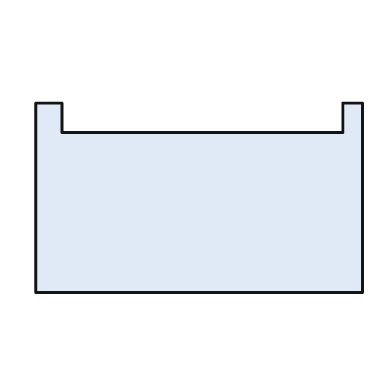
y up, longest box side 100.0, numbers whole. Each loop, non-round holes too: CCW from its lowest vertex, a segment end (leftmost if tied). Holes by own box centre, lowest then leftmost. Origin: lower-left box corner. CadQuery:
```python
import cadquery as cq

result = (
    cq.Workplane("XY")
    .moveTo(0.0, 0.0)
    .lineTo(100.0, 0.0)
    .lineTo(100.0, 58.0)
    .lineTo(94.0, 58.0)
    .lineTo(94.0, 49.0)
    .lineTo(8.0, 49.0)
    .lineTo(8.0, 58.0)
    .lineTo(0.0, 58.0)
    .close()
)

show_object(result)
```